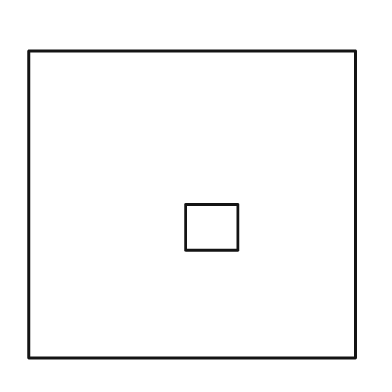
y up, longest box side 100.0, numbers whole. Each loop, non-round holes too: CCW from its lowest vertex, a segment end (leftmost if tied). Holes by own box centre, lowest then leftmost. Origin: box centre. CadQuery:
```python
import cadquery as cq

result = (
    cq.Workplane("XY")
    .moveTo(-50.0, -47.0)
    .lineTo(50.0, -47.0)
    .lineTo(50.0, 47.0)
    .lineTo(-50.0, 47.0)
    .close()
    .moveTo(-2.0, -14.0)
    .lineTo(14.0, -14.0)
    .lineTo(14.0, 0.0)
    .lineTo(-2.0, 0.0)
    .close()
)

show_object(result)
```